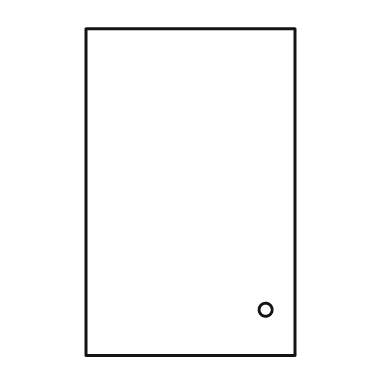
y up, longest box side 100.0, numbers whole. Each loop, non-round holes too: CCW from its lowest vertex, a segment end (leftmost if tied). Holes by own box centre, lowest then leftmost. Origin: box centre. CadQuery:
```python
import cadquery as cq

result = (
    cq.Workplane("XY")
    .moveTo(-32.0, -50.0)
    .lineTo(32.0, -50.0)
    .lineTo(32.0, 50.0)
    .lineTo(-32.0, 50.0)
    .close()
    .moveTo(23.0, -36.0)
    .circle(2.0)
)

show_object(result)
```